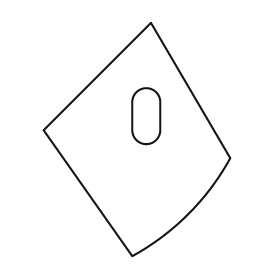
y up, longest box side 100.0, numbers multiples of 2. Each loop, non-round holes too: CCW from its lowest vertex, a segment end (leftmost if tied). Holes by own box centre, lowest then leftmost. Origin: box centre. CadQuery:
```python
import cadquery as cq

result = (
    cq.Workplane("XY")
    .moveTo(-2.0, -50.0)
    .threePointArc((22.0, -32.0), (40.0, -8.0))
    .lineTo(6.0, 50.0)
    .lineTo(-40.0, 4.0)
    .close()
    .moveTo(-2.0, 4.0)
    .threePointArc((4.0, -2.0), (10.0, 4.0))
    .lineTo(10.0, 16.0)
    .threePointArc((4.0, 22.0), (-2.0, 16.0))
    .close()
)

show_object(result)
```